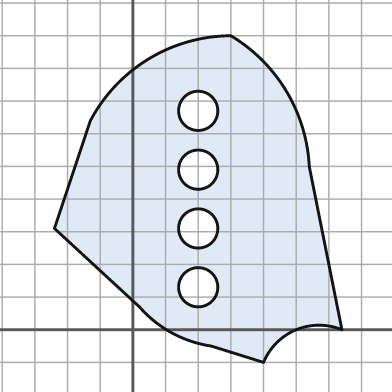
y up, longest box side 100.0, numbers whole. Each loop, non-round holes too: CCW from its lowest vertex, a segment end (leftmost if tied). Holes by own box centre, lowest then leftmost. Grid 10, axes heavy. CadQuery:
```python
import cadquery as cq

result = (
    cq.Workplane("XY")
    .moveTo(40.0, -10.0)
    .threePointArc((50.0, 0.0), (64.0, 0.0))
    .lineTo(54.0, 50.0)
    .threePointArc((47.0, 73.0), (30.0, 90.0))
    .threePointArc((5.0, 83.0), (-13.0, 64.0))
    .lineTo(-24.0, 31.0)
    .lineTo(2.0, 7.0)
    .threePointArc((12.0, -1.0), (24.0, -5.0))
    .close()
    .moveTo(20.0, 13.0)
    .circle(6.0)
    .moveTo(20.0, 31.0)
    .circle(6.0)
    .moveTo(20.0, 49.0)
    .circle(6.0)
    .moveTo(20.0, 67.0)
    .circle(6.0)
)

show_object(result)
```